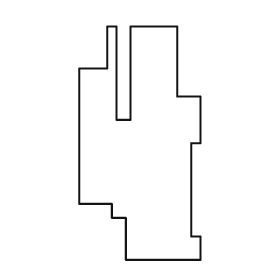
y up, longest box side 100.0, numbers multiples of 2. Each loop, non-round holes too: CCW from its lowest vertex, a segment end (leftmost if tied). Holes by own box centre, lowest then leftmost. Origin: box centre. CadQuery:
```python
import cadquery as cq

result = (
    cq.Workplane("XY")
    .moveTo(-6.0, -50.0)
    .lineTo(26.0, -50.0)
    .lineTo(26.0, -40.0)
    .lineTo(22.0, -40.0)
    .lineTo(22.0, 0.0)
    .lineTo(26.0, 0.0)
    .lineTo(26.0, 20.0)
    .lineTo(16.0, 20.0)
    .lineTo(16.0, 50.0)
    .lineTo(-4.0, 50.0)
    .lineTo(-4.0, 10.0)
    .lineTo(-10.0, 10.0)
    .lineTo(-10.0, 50.0)
    .lineTo(-14.0, 50.0)
    .lineTo(-14.0, 32.0)
    .lineTo(-26.0, 32.0)
    .lineTo(-26.0, -26.0)
    .lineTo(-12.0, -26.0)
    .lineTo(-12.0, -32.0)
    .lineTo(-6.0, -32.0)
    .close()
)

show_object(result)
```